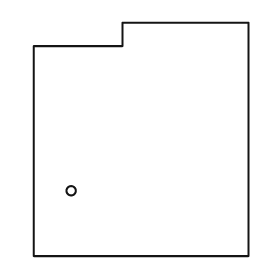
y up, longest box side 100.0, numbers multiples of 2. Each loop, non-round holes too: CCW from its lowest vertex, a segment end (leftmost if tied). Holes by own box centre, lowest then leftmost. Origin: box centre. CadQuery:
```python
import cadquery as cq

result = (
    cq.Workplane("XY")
    .moveTo(-46.0, -50.0)
    .lineTo(46.0, -50.0)
    .lineTo(46.0, 50.0)
    .lineTo(-8.0, 50.0)
    .lineTo(-8.0, 40.0)
    .lineTo(-46.0, 40.0)
    .close()
    .moveTo(-30.0, -22.0)
    .circle(2.0)
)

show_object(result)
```